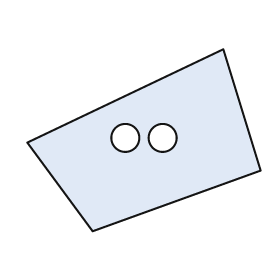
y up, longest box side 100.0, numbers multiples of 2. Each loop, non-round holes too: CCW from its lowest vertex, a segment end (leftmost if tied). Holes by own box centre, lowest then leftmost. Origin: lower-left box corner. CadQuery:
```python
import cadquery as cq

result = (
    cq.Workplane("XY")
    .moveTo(28.0, 0.0)
    .lineTo(100.0, 26.0)
    .lineTo(84.0, 78.0)
    .lineTo(0.0, 38.0)
    .close()
    .moveTo(42.0, 40.0)
    .circle(6.0)
    .moveTo(58.0, 40.0)
    .circle(6.0)
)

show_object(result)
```